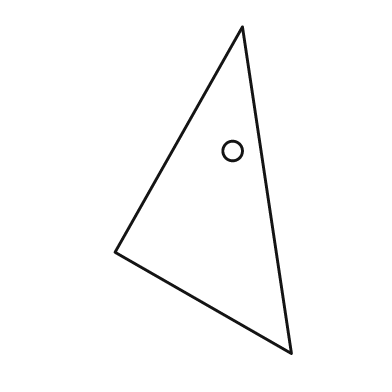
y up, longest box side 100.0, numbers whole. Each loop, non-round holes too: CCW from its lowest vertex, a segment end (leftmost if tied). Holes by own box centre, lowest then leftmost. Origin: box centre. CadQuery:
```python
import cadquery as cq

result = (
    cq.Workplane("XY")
    .moveTo(27.0, -50.0)
    .lineTo(12.0, 50.0)
    .lineTo(-27.0, -19.0)
    .close()
    .moveTo(9.0, 12.0)
    .circle(3.0)
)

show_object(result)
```